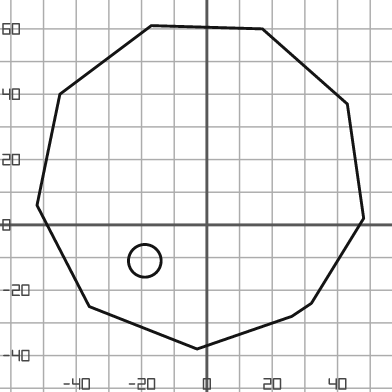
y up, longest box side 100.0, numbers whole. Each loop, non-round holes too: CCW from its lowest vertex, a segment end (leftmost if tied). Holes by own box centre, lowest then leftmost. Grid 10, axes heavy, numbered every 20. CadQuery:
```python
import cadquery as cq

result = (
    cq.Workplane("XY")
    .moveTo(-3.0, -38.0)
    .lineTo(26.0, -28.0)
    .lineTo(32.0, -24.0)
    .lineTo(48.0, 2.0)
    .lineTo(43.0, 37.0)
    .lineTo(17.0, 60.0)
    .lineTo(-17.0, 61.0)
    .lineTo(-45.0, 40.0)
    .lineTo(-52.0, 6.0)
    .lineTo(-36.0, -25.0)
    .close()
    .moveTo(-19.0, -11.0)
    .circle(5.0)
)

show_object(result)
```